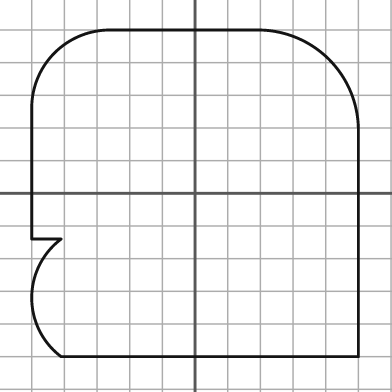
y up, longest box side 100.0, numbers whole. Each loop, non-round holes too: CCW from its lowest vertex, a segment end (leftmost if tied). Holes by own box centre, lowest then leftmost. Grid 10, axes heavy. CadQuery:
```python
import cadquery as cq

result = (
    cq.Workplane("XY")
    .moveTo(-41.0, -50.0)
    .lineTo(50.0, -50.0)
    .lineTo(50.0, 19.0)
    .threePointArc((41.0, 41.0), (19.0, 50.0))
    .lineTo(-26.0, 50.0)
    .threePointArc((-43.0, 43.0), (-50.0, 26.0))
    .lineTo(-50.0, -14.0)
    .lineTo(-41.0, -14.0)
    .threePointArc((-50.0, -32.0), (-41.0, -50.0))
    .close()
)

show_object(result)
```